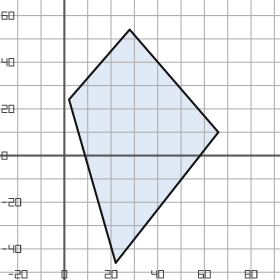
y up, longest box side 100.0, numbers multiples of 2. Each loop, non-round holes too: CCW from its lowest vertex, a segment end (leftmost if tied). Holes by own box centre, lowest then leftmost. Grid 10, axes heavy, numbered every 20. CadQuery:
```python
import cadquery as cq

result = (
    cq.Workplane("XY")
    .moveTo(22.0, -46.0)
    .lineTo(66.0, 10.0)
    .lineTo(28.0, 54.0)
    .lineTo(2.0, 24.0)
    .close()
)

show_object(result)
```